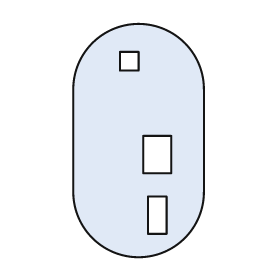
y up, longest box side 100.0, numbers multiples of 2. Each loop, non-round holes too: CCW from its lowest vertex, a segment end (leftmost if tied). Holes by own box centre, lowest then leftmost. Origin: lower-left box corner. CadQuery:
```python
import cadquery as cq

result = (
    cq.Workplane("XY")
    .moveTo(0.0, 28.0)
    .threePointArc((28.0, 0.0), (56.0, 28.0))
    .lineTo(56.0, 72.0)
    .threePointArc((28.0, 100.0), (0.0, 72.0))
    .close()
    .moveTo(32.0, 10.0)
    .lineTo(40.0, 10.0)
    .lineTo(40.0, 26.0)
    .lineTo(32.0, 26.0)
    .close()
    .moveTo(30.0, 36.0)
    .lineTo(42.0, 36.0)
    .lineTo(42.0, 52.0)
    .lineTo(30.0, 52.0)
    .close()
    .moveTo(20.0, 80.0)
    .lineTo(28.0, 80.0)
    .lineTo(28.0, 88.0)
    .lineTo(20.0, 88.0)
    .close()
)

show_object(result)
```